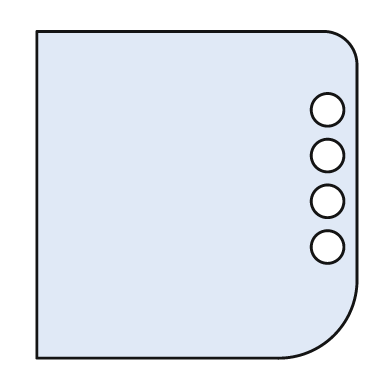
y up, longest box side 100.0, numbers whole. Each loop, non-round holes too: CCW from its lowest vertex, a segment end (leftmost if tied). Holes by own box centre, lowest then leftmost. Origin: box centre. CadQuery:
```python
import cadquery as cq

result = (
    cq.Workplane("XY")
    .moveTo(-49.0, -50.0)
    .lineTo(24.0, -50.0)
    .threePointArc((42.0, -43.0), (49.0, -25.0))
    .lineTo(49.0, 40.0)
    .threePointArc((46.0, 47.0), (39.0, 50.0))
    .lineTo(-49.0, 50.0)
    .close()
    .moveTo(40.0, -16.0)
    .circle(5.0)
    .moveTo(40.0, -2.0)
    .circle(5.0)
    .moveTo(40.0, 12.0)
    .circle(5.0)
    .moveTo(40.0, 26.0)
    .circle(5.0)
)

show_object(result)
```